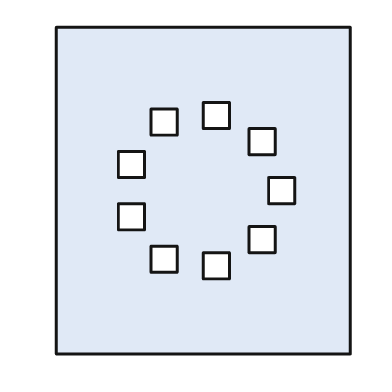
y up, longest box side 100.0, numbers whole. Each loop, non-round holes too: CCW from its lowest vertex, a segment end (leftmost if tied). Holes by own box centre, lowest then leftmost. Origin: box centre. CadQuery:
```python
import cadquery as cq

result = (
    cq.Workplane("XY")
    .moveTo(-45.0, -50.0)
    .lineTo(45.0, -50.0)
    .lineTo(45.0, 50.0)
    .lineTo(-45.0, 50.0)
    .close()
    .moveTo(0.0, -27.0)
    .lineTo(8.0, -27.0)
    .lineTo(8.0, -19.0)
    .lineTo(0.0, -19.0)
    .close()
    .moveTo(-16.0, -25.0)
    .lineTo(-8.0, -25.0)
    .lineTo(-8.0, -17.0)
    .lineTo(-16.0, -17.0)
    .close()
    .moveTo(14.0, -19.0)
    .lineTo(22.0, -19.0)
    .lineTo(22.0, -11.0)
    .lineTo(14.0, -11.0)
    .close()
    .moveTo(-26.0, -12.0)
    .lineTo(-18.0, -12.0)
    .lineTo(-18.0, -4.0)
    .lineTo(-26.0, -4.0)
    .close()
    .moveTo(20.0, -4.0)
    .lineTo(28.0, -4.0)
    .lineTo(28.0, 4.0)
    .lineTo(20.0, 4.0)
    .close()
    .moveTo(-26.0, 4.0)
    .lineTo(-18.0, 4.0)
    .lineTo(-18.0, 12.0)
    .lineTo(-26.0, 12.0)
    .close()
    .moveTo(14.0, 11.0)
    .lineTo(22.0, 11.0)
    .lineTo(22.0, 19.0)
    .lineTo(14.0, 19.0)
    .close()
    .moveTo(-16.0, 17.0)
    .lineTo(-8.0, 17.0)
    .lineTo(-8.0, 25.0)
    .lineTo(-16.0, 25.0)
    .close()
    .moveTo(0.0, 19.0)
    .lineTo(8.0, 19.0)
    .lineTo(8.0, 27.0)
    .lineTo(0.0, 27.0)
    .close()
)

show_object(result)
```